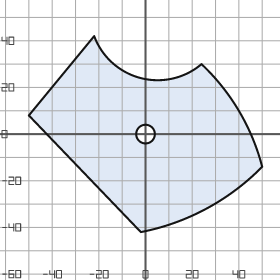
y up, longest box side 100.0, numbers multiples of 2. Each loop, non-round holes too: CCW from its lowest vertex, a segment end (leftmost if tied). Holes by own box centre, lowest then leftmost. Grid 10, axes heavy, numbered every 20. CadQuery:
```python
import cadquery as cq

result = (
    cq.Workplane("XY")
    .moveTo(-2.0, -42.0)
    .threePointArc((26.0, -32.0), (50.0, -14.0))
    .threePointArc((40.0, 10.0), (24.0, 30.0))
    .threePointArc((-2.0, 24.0), (-22.0, 42.0))
    .lineTo(-50.0, 8.0)
    .close()
    .moveTo(0.0, 0.0)
    .circle(4.0)
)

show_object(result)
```